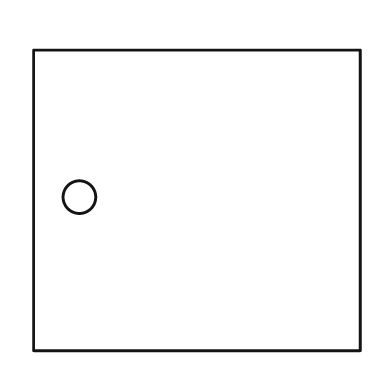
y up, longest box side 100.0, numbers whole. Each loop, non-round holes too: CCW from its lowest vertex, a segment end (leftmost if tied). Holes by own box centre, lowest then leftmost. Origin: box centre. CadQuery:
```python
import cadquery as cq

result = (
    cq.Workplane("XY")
    .moveTo(-50.0, -46.0)
    .lineTo(50.0, -46.0)
    .lineTo(50.0, 46.0)
    .lineTo(-50.0, 46.0)
    .close()
    .moveTo(-36.0, 1.0)
    .circle(5.0)
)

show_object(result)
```